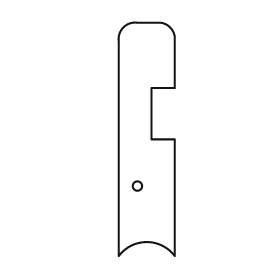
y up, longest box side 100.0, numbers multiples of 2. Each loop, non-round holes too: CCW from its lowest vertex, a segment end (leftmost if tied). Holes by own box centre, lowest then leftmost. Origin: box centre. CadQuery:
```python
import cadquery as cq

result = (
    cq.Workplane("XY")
    .moveTo(-12.0, -50.0)
    .threePointArc((0.0, -44.0), (12.0, -50.0))
    .lineTo(12.0, 0.0)
    .lineTo(2.0, 0.0)
    .lineTo(2.0, 22.0)
    .lineTo(12.0, 22.0)
    .lineTo(12.0, 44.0)
    .threePointArc((10.0, 48.0), (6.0, 50.0))
    .lineTo(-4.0, 50.0)
    .threePointArc((-10.0, 48.0), (-12.0, 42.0))
    .close()
    .moveTo(-4.0, -20.0)
    .circle(2.0)
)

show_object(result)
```